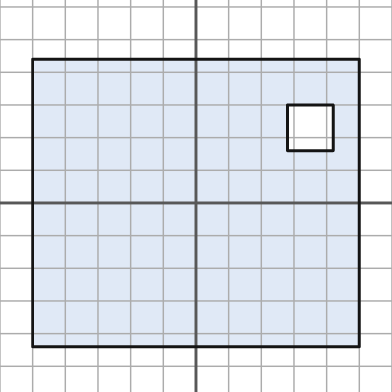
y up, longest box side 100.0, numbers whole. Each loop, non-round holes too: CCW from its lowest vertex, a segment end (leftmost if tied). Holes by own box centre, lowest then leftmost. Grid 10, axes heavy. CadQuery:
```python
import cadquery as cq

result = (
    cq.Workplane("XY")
    .moveTo(-50.0, -44.0)
    .lineTo(50.0, -44.0)
    .lineTo(50.0, 44.0)
    .lineTo(-50.0, 44.0)
    .close()
    .moveTo(28.0, 16.0)
    .lineTo(42.0, 16.0)
    .lineTo(42.0, 30.0)
    .lineTo(28.0, 30.0)
    .close()
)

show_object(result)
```